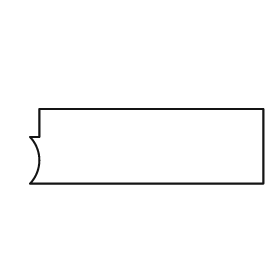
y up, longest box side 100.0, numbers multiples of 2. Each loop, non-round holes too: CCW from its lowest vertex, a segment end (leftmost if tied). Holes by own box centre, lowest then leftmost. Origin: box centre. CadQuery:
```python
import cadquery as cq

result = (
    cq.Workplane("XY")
    .moveTo(-50.0, -16.0)
    .lineTo(50.0, -16.0)
    .lineTo(50.0, 16.0)
    .lineTo(-46.0, 16.0)
    .lineTo(-46.0, 4.0)
    .lineTo(-50.0, 4.0)
    .threePointArc((-46.0, -6.0), (-50.0, -16.0))
    .close()
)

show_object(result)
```